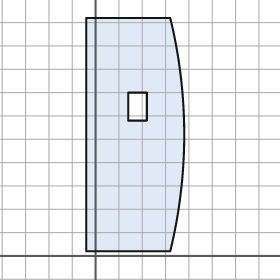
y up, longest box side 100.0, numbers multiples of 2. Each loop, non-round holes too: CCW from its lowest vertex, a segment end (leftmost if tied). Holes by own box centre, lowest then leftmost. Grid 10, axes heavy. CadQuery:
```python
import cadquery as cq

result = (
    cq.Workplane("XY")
    .moveTo(-4.0, 2.0)
    .lineTo(32.0, 2.0)
    .threePointArc((38.0, 52.0), (32.0, 102.0))
    .lineTo(-4.0, 102.0)
    .close()
    .moveTo(14.0, 58.0)
    .lineTo(22.0, 58.0)
    .lineTo(22.0, 70.0)
    .lineTo(14.0, 70.0)
    .close()
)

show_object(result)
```